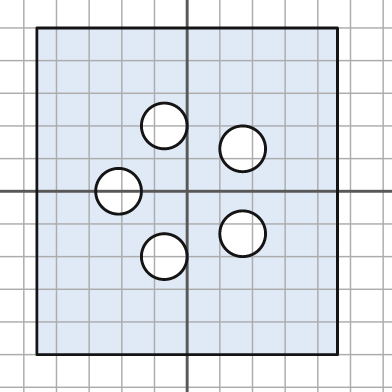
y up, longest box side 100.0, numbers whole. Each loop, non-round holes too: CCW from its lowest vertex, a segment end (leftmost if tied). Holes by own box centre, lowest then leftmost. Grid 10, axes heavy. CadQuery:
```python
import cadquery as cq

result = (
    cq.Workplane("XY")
    .moveTo(-46.0, -50.0)
    .lineTo(46.0, -50.0)
    .lineTo(46.0, 50.0)
    .lineTo(-46.0, 50.0)
    .close()
    .moveTo(-7.0, -20.0)
    .circle(7.0)
    .moveTo(17.0, -13.0)
    .circle(7.0)
    .moveTo(-21.0, 0.0)
    .circle(7.0)
    .moveTo(17.0, 13.0)
    .circle(7.0)
    .moveTo(-7.0, 20.0)
    .circle(7.0)
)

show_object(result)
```